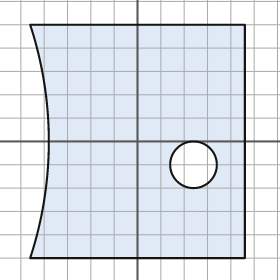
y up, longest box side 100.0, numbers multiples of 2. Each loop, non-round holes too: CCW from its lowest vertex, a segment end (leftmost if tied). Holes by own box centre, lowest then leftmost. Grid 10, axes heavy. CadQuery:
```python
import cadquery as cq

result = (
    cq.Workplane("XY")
    .moveTo(-46.0, -50.0)
    .lineTo(46.0, -50.0)
    .lineTo(46.0, 50.0)
    .lineTo(-46.0, 50.0)
    .threePointArc((-38.0, 0.0), (-46.0, -50.0))
    .close()
    .moveTo(24.0, -10.0)
    .circle(10.0)
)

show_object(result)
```